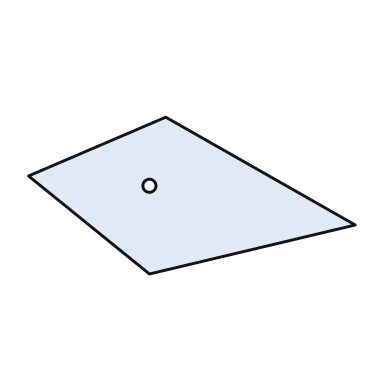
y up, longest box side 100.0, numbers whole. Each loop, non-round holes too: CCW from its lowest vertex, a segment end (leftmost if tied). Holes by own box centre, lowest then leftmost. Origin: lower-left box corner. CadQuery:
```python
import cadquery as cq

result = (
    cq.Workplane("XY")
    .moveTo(37.0, 0.0)
    .lineTo(100.0, 15.0)
    .lineTo(42.0, 48.0)
    .lineTo(0.0, 30.0)
    .close()
    .moveTo(37.0, 27.0)
    .circle(2.0)
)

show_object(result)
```